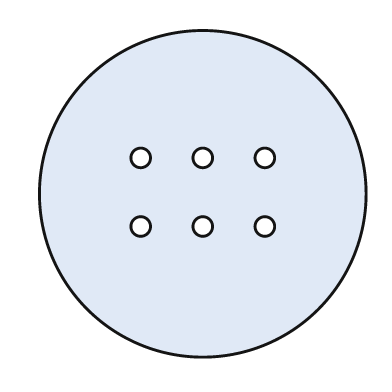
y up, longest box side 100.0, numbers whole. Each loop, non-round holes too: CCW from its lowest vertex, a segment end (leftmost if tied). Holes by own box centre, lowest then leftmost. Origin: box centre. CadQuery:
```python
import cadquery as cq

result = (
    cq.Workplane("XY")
    .moveTo(0.0, 0.0)
    .circle(50.0)
    .moveTo(-19.0, -10.0)
    .circle(3.0)
    .moveTo(0.0, -10.0)
    .circle(3.0)
    .moveTo(19.0, -10.0)
    .circle(3.0)
    .moveTo(-19.0, 11.0)
    .circle(3.0)
    .moveTo(0.0, 11.0)
    .circle(3.0)
    .moveTo(19.0, 11.0)
    .circle(3.0)
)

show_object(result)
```